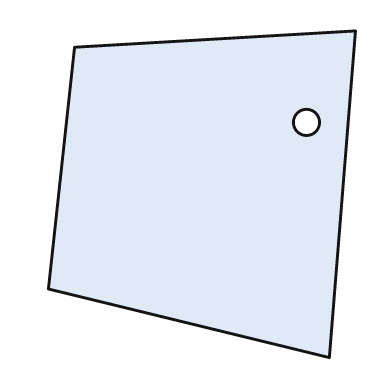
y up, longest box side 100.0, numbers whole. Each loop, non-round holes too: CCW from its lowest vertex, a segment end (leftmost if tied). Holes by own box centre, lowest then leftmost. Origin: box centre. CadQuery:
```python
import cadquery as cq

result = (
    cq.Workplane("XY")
    .moveTo(39.0, -50.0)
    .lineTo(47.0, 50.0)
    .lineTo(-39.0, 45.0)
    .lineTo(-47.0, -29.0)
    .close()
    .moveTo(32.0, 22.0)
    .circle(4.0)
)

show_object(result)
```